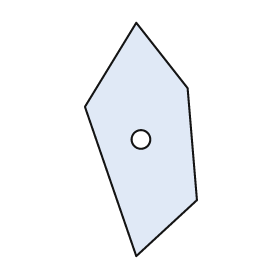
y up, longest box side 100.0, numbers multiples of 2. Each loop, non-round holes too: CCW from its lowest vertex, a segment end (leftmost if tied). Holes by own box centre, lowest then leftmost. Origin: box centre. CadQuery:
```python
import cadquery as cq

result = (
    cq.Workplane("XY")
    .moveTo(-2.0, -50.0)
    .lineTo(24.0, -26.0)
    .lineTo(20.0, 22.0)
    .lineTo(-2.0, 50.0)
    .lineTo(-24.0, 14.0)
    .close()
    .moveTo(0.0, 0.0)
    .circle(4.0)
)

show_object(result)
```